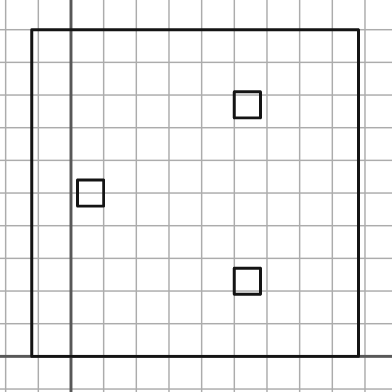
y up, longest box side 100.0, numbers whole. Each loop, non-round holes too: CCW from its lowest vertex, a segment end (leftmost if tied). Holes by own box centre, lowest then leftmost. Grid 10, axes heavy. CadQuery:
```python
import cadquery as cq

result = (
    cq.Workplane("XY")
    .moveTo(-12.0, 0.0)
    .lineTo(88.0, 0.0)
    .lineTo(88.0, 100.0)
    .lineTo(-12.0, 100.0)
    .close()
    .moveTo(50.0, 19.0)
    .lineTo(58.0, 19.0)
    .lineTo(58.0, 27.0)
    .lineTo(50.0, 27.0)
    .close()
    .moveTo(2.0, 46.0)
    .lineTo(10.0, 46.0)
    .lineTo(10.0, 54.0)
    .lineTo(2.0, 54.0)
    .close()
    .moveTo(50.0, 73.0)
    .lineTo(58.0, 73.0)
    .lineTo(58.0, 81.0)
    .lineTo(50.0, 81.0)
    .close()
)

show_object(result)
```